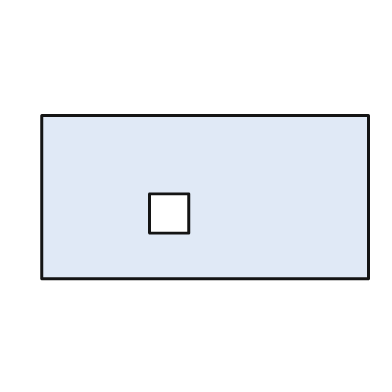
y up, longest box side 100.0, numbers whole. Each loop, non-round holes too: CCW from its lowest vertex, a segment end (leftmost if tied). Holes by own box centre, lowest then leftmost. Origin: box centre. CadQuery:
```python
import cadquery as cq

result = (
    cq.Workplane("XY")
    .moveTo(-50.0, -25.0)
    .lineTo(50.0, -25.0)
    .lineTo(50.0, 25.0)
    .lineTo(-50.0, 25.0)
    .close()
    .moveTo(-17.0, -11.0)
    .lineTo(-5.0, -11.0)
    .lineTo(-5.0, 1.0)
    .lineTo(-17.0, 1.0)
    .close()
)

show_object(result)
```